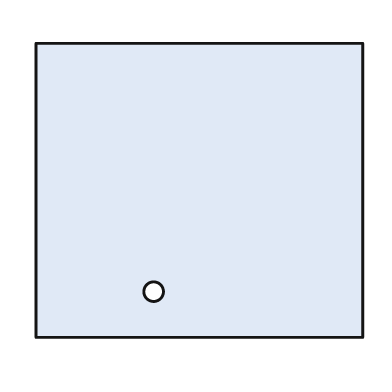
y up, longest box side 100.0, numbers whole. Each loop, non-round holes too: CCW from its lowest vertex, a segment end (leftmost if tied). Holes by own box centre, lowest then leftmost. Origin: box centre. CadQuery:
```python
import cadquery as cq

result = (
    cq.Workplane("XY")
    .moveTo(-50.0, -45.0)
    .lineTo(50.0, -45.0)
    .lineTo(50.0, 45.0)
    .lineTo(-50.0, 45.0)
    .close()
    .moveTo(-14.0, -31.0)
    .circle(3.0)
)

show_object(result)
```